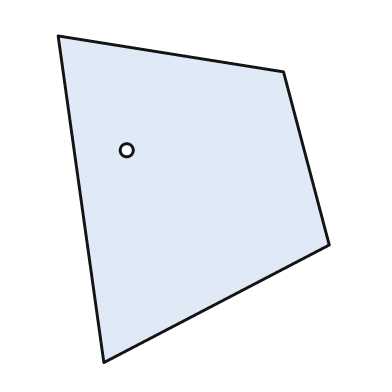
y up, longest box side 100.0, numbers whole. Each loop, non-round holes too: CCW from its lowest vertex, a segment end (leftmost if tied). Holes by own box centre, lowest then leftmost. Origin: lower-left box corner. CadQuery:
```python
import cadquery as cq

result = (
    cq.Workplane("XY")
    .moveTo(14.0, 0.0)
    .lineTo(83.0, 36.0)
    .lineTo(69.0, 89.0)
    .lineTo(0.0, 100.0)
    .close()
    .moveTo(21.0, 65.0)
    .circle(2.0)
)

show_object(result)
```